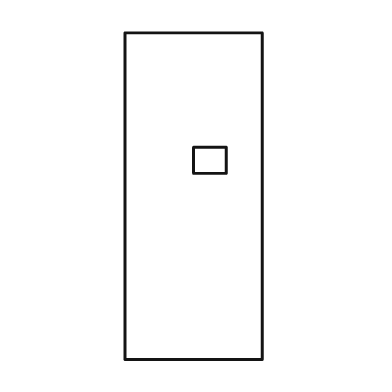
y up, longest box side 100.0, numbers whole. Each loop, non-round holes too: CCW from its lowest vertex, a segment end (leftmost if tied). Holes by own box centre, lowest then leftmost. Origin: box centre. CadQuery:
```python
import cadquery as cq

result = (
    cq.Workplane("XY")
    .moveTo(-21.0, -50.0)
    .lineTo(21.0, -50.0)
    .lineTo(21.0, 50.0)
    .lineTo(-21.0, 50.0)
    .close()
    .moveTo(0.0, 7.0)
    .lineTo(10.0, 7.0)
    .lineTo(10.0, 15.0)
    .lineTo(0.0, 15.0)
    .close()
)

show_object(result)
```